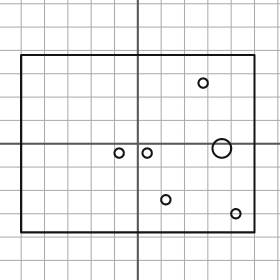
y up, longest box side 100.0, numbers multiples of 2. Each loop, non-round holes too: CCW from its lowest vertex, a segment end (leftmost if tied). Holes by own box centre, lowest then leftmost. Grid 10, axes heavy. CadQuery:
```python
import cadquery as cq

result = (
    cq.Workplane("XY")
    .moveTo(-50.0, -38.0)
    .lineTo(50.0, -38.0)
    .lineTo(50.0, 38.0)
    .lineTo(-50.0, 38.0)
    .close()
    .moveTo(42.0, -30.0)
    .circle(2.0)
    .moveTo(12.0, -24.0)
    .circle(2.0)
    .moveTo(-8.0, -4.0)
    .circle(2.0)
    .moveTo(4.0, -4.0)
    .circle(2.0)
    .moveTo(36.0, -2.0)
    .circle(4.0)
    .moveTo(28.0, 26.0)
    .circle(2.0)
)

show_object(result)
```